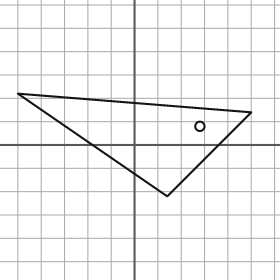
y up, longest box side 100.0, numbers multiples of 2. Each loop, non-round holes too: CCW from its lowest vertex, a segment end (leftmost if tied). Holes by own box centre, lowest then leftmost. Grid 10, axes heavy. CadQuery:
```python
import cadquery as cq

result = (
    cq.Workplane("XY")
    .moveTo(14.0, -22.0)
    .lineTo(50.0, 14.0)
    .lineTo(-50.0, 22.0)
    .close()
    .moveTo(28.0, 8.0)
    .circle(2.0)
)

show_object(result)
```